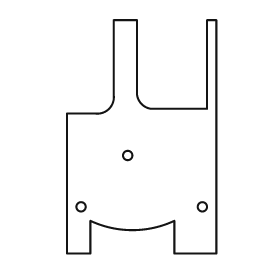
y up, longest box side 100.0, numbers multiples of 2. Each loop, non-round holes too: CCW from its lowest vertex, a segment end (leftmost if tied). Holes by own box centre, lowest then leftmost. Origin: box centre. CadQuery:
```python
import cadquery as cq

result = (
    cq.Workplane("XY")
    .moveTo(-32.0, -50.0)
    .lineTo(-22.0, -50.0)
    .lineTo(-22.0, -36.0)
    .threePointArc((-4.0, -40.0), (14.0, -36.0))
    .lineTo(14.0, -50.0)
    .lineTo(32.0, -50.0)
    .lineTo(32.0, 50.0)
    .lineTo(28.0, 50.0)
    .lineTo(28.0, 12.0)
    .lineTo(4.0, 12.0)
    .threePointArc((0.0, 14.0), (-2.0, 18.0))
    .lineTo(-2.0, 50.0)
    .lineTo(-12.0, 50.0)
    .lineTo(-12.0, 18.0)
    .threePointArc((-14.0, 12.0), (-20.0, 10.0))
    .lineTo(-32.0, 10.0)
    .close()
    .moveTo(-26.0, -30.0)
    .circle(2.0)
    .moveTo(26.0, -30.0)
    .circle(2.0)
    .moveTo(-6.0, -8.0)
    .circle(2.0)
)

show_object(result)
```